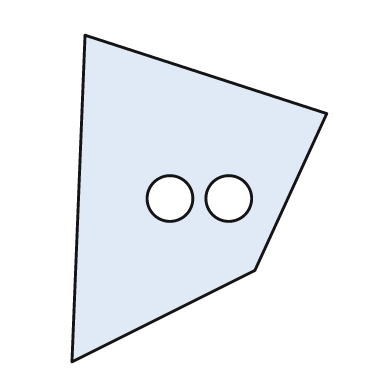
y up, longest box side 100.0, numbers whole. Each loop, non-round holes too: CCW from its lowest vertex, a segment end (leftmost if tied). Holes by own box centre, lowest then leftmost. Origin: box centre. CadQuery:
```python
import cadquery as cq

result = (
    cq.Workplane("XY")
    .moveTo(-39.0, -50.0)
    .lineTo(17.0, -22.0)
    .lineTo(39.0, 26.0)
    .lineTo(-35.0, 50.0)
    .close()
    .moveTo(-9.0, 0.0)
    .circle(7.0)
    .moveTo(9.0, 0.0)
    .circle(7.0)
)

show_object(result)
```